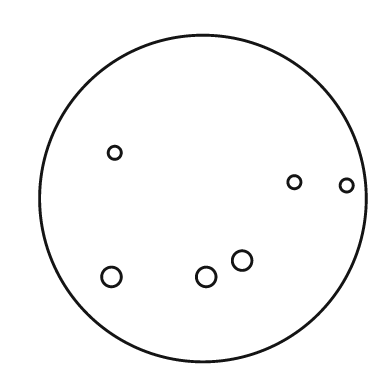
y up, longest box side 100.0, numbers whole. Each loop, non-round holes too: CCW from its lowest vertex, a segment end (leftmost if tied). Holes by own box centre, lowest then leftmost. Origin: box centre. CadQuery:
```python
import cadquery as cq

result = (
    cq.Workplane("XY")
    .moveTo(0.0, 0.0)
    .circle(50.0)
    .moveTo(-28.0, -24.0)
    .circle(3.0)
    .moveTo(1.0, -24.0)
    .circle(3.0)
    .moveTo(12.0, -19.0)
    .circle(3.0)
    .moveTo(44.0, 4.0)
    .circle(2.0)
    .moveTo(28.0, 5.0)
    .circle(2.0)
    .moveTo(-27.0, 14.0)
    .circle(2.0)
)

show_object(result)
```